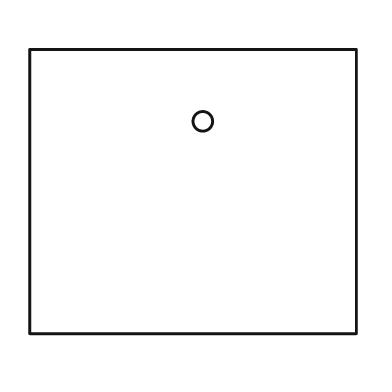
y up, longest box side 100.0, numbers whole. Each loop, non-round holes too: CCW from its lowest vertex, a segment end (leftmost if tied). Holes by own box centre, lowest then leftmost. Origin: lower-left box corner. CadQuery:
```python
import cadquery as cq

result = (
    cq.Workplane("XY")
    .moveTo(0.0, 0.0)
    .lineTo(100.0, 0.0)
    .lineTo(100.0, 87.0)
    .lineTo(0.0, 87.0)
    .close()
    .moveTo(53.0, 65.0)
    .circle(3.0)
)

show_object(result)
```